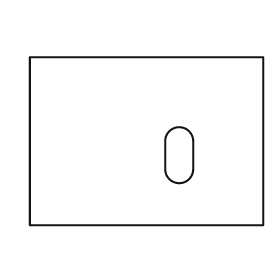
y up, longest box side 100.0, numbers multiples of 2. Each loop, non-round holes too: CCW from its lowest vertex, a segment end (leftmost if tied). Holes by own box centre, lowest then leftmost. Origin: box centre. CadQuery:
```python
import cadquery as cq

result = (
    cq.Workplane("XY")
    .moveTo(-50.0, -36.0)
    .lineTo(50.0, -36.0)
    .lineTo(50.0, 36.0)
    .lineTo(-50.0, 36.0)
    .close()
    .moveTo(8.0, -12.0)
    .threePointArc((14.0, -18.0), (20.0, -12.0))
    .lineTo(20.0, 0.0)
    .threePointArc((14.0, 6.0), (8.0, 0.0))
    .close()
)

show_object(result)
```